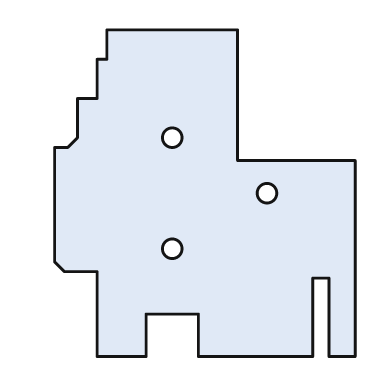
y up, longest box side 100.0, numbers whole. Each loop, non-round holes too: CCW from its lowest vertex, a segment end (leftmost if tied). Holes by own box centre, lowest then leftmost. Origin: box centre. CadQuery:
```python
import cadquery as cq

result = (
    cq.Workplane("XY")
    .moveTo(-33.0, -50.0)
    .lineTo(-18.0, -50.0)
    .lineTo(-18.0, -37.0)
    .lineTo(-2.0, -37.0)
    .lineTo(-2.0, -50.0)
    .lineTo(33.0, -50.0)
    .lineTo(33.0, -26.0)
    .lineTo(38.0, -26.0)
    .lineTo(38.0, -50.0)
    .lineTo(46.0, -50.0)
    .lineTo(46.0, 10.0)
    .lineTo(10.0, 10.0)
    .lineTo(10.0, 50.0)
    .lineTo(-30.0, 50.0)
    .lineTo(-30.0, 41.0)
    .lineTo(-33.0, 41.0)
    .lineTo(-33.0, 29.0)
    .lineTo(-39.0, 29.0)
    .lineTo(-39.0, 17.0)
    .lineTo(-42.0, 14.0)
    .lineTo(-46.0, 14.0)
    .lineTo(-46.0, -21.0)
    .lineTo(-43.0, -24.0)
    .lineTo(-33.0, -24.0)
    .close()
    .moveTo(-10.0, -17.0)
    .circle(3.0)
    .moveTo(19.0, 0.0)
    .circle(3.0)
    .moveTo(-10.0, 17.0)
    .circle(3.0)
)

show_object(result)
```